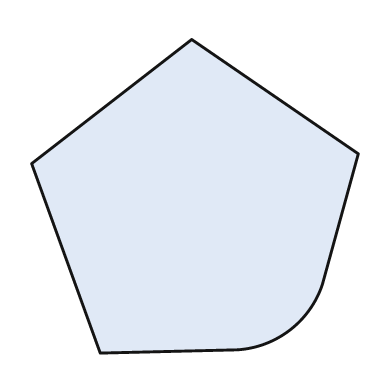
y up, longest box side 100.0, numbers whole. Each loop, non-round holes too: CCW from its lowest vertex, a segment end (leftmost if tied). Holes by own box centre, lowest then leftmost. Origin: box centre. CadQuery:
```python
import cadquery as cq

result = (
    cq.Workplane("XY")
    .moveTo(-29.0, -48.0)
    .lineTo(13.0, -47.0)
    .threePointArc((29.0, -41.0), (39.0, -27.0))
    .lineTo(50.0, 13.0)
    .lineTo(-1.0, 48.0)
    .lineTo(-50.0, 10.0)
    .close()
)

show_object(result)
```